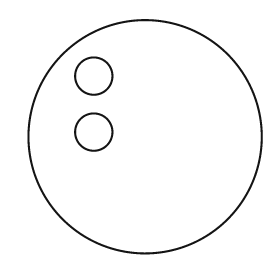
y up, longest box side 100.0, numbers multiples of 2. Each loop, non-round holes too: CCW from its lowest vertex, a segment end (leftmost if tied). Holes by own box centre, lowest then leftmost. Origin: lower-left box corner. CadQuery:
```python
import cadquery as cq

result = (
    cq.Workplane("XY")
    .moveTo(50.0, 50.0)
    .circle(50.0)
    .moveTo(28.0, 52.0)
    .circle(8.0)
    .moveTo(28.0, 76.0)
    .circle(8.0)
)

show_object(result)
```